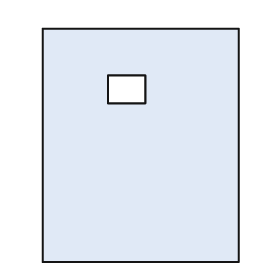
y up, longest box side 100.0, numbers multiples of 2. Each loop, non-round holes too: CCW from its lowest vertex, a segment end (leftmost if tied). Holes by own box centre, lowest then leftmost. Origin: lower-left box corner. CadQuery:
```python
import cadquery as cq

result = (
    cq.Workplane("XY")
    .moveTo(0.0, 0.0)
    .lineTo(84.0, 0.0)
    .lineTo(84.0, 100.0)
    .lineTo(0.0, 100.0)
    .close()
    .moveTo(28.0, 68.0)
    .lineTo(44.0, 68.0)
    .lineTo(44.0, 80.0)
    .lineTo(28.0, 80.0)
    .close()
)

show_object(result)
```